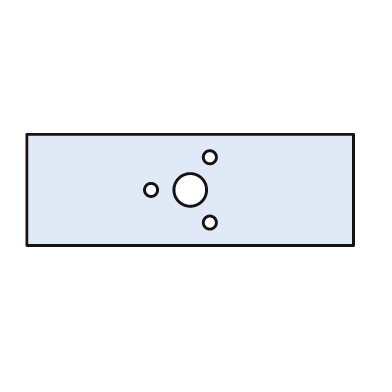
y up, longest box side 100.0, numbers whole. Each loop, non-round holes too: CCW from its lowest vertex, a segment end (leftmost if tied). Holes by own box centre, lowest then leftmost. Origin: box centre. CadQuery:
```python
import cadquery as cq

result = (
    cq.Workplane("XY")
    .moveTo(-50.0, -17.0)
    .lineTo(50.0, -17.0)
    .lineTo(50.0, 17.0)
    .lineTo(-50.0, 17.0)
    .close()
    .moveTo(6.0, -10.0)
    .circle(2.0)
    .moveTo(-12.0, 0.0)
    .circle(2.0)
    .moveTo(0.0, 0.0)
    .circle(5.0)
    .moveTo(6.0, 10.0)
    .circle(2.0)
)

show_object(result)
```